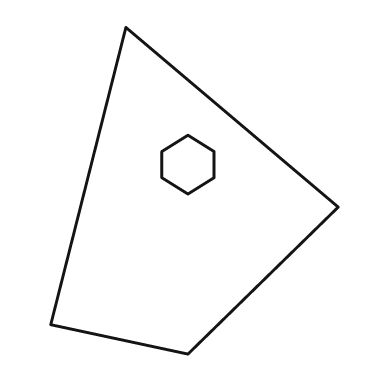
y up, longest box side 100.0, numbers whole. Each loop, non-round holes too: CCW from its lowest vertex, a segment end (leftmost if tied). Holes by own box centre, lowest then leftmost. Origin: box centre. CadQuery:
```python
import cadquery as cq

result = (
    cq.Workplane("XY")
    .moveTo(-2.0, -50.0)
    .lineTo(44.0, -5.0)
    .lineTo(-21.0, 50.0)
    .lineTo(-44.0, -41.0)
    .close()
    .moveTo(-2.0, -1.0)
    .lineTo(6.0, 4.0)
    .lineTo(6.0, 12.0)
    .lineTo(-2.0, 17.0)
    .lineTo(-10.0, 12.0)
    .lineTo(-10.0, 4.0)
    .close()
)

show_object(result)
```